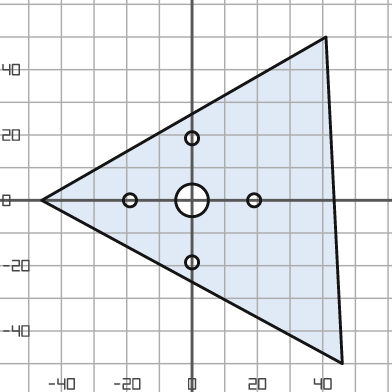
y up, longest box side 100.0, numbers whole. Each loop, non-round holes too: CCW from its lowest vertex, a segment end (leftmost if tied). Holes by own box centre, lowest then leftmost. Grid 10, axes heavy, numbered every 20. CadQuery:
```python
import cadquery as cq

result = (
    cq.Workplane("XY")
    .moveTo(46.0, -50.0)
    .lineTo(41.0, 50.0)
    .lineTo(-46.0, 0.0)
    .close()
    .moveTo(0.0, -19.0)
    .circle(2.0)
    .moveTo(-19.0, 0.0)
    .circle(2.0)
    .moveTo(0.0, 0.0)
    .circle(5.0)
    .moveTo(19.0, 0.0)
    .circle(2.0)
    .moveTo(0.0, 19.0)
    .circle(2.0)
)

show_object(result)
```